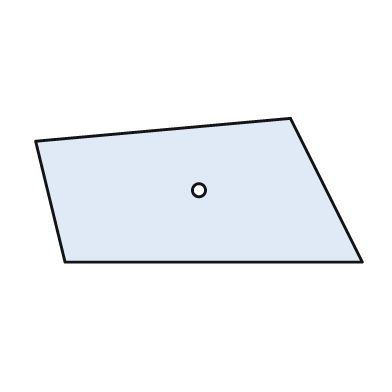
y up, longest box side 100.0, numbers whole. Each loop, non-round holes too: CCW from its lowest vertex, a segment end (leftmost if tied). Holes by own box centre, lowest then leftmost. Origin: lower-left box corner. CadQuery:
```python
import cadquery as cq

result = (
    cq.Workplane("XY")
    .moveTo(9.0, 0.0)
    .lineTo(100.0, 0.0)
    .lineTo(78.0, 44.0)
    .lineTo(0.0, 37.0)
    .close()
    .moveTo(50.0, 22.0)
    .circle(2.0)
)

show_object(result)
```